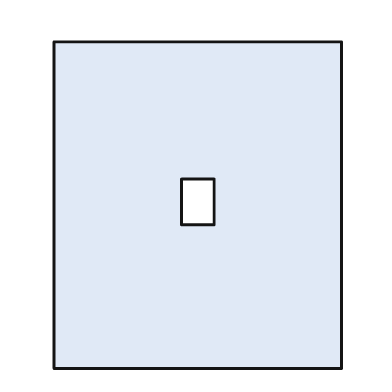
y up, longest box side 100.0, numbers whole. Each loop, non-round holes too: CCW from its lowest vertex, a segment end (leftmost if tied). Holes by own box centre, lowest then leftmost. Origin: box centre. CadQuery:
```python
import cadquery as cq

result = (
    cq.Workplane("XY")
    .moveTo(-44.0, -50.0)
    .lineTo(44.0, -50.0)
    .lineTo(44.0, 50.0)
    .lineTo(-44.0, 50.0)
    .close()
    .moveTo(-5.0, -6.0)
    .lineTo(5.0, -6.0)
    .lineTo(5.0, 8.0)
    .lineTo(-5.0, 8.0)
    .close()
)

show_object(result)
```